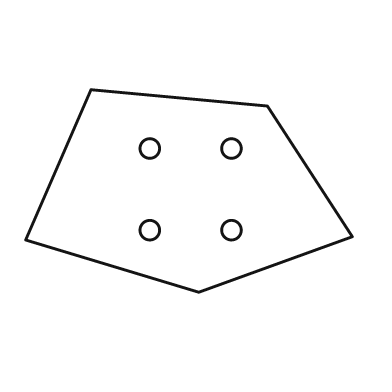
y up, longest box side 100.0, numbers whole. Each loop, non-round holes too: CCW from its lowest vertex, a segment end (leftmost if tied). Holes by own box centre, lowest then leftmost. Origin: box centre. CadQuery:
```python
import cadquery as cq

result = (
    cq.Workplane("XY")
    .moveTo(3.0, -31.0)
    .lineTo(50.0, -14.0)
    .lineTo(24.0, 26.0)
    .lineTo(-30.0, 31.0)
    .lineTo(-50.0, -15.0)
    .close()
    .moveTo(-12.0, -12.0)
    .circle(3.0)
    .moveTo(13.0, -12.0)
    .circle(3.0)
    .moveTo(-12.0, 13.0)
    .circle(3.0)
    .moveTo(13.0, 13.0)
    .circle(3.0)
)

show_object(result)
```